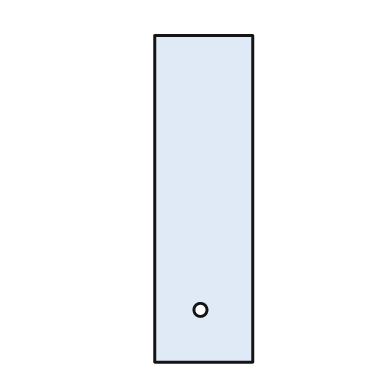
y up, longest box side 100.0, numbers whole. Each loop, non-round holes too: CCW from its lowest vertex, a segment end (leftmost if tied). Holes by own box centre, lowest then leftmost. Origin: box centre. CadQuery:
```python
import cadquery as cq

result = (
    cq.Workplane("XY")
    .moveTo(-15.0, -50.0)
    .lineTo(15.0, -50.0)
    .lineTo(15.0, 50.0)
    .lineTo(-15.0, 50.0)
    .close()
    .moveTo(-1.0, -34.0)
    .circle(2.0)
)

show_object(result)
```